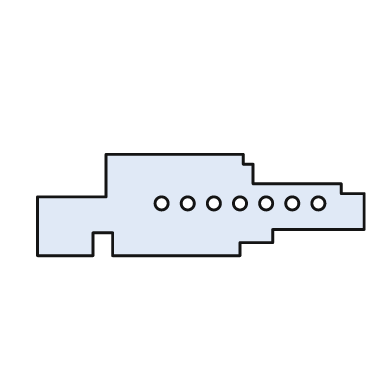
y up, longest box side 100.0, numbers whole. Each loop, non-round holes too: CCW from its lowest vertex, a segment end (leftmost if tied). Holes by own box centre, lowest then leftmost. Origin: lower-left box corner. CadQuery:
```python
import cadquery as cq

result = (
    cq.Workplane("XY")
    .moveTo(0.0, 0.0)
    .lineTo(17.0, 0.0)
    .lineTo(17.0, 7.0)
    .lineTo(23.0, 7.0)
    .lineTo(23.0, 0.0)
    .lineTo(62.0, 0.0)
    .lineTo(62.0, 4.0)
    .lineTo(72.0, 4.0)
    .lineTo(72.0, 8.0)
    .lineTo(100.0, 8.0)
    .lineTo(100.0, 19.0)
    .lineTo(93.0, 19.0)
    .lineTo(93.0, 22.0)
    .lineTo(66.0, 22.0)
    .lineTo(66.0, 28.0)
    .lineTo(63.0, 28.0)
    .lineTo(63.0, 31.0)
    .lineTo(21.0, 31.0)
    .lineTo(21.0, 18.0)
    .lineTo(0.0, 18.0)
    .close()
    .moveTo(38.0, 16.0)
    .circle(2.0)
    .moveTo(46.0, 16.0)
    .circle(2.0)
    .moveTo(54.0, 16.0)
    .circle(2.0)
    .moveTo(62.0, 16.0)
    .circle(2.0)
    .moveTo(70.0, 16.0)
    .circle(2.0)
    .moveTo(78.0, 16.0)
    .circle(2.0)
    .moveTo(86.0, 16.0)
    .circle(2.0)
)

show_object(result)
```